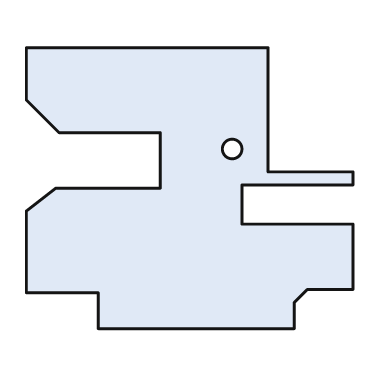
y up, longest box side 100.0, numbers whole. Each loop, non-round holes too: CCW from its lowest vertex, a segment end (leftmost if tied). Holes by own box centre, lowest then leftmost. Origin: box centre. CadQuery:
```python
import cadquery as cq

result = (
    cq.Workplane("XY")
    .moveTo(-28.0, -43.0)
    .lineTo(32.0, -43.0)
    .lineTo(32.0, -35.0)
    .lineTo(36.0, -31.0)
    .lineTo(50.0, -31.0)
    .lineTo(50.0, -11.0)
    .lineTo(16.0, -11.0)
    .lineTo(16.0, 1.0)
    .lineTo(50.0, 1.0)
    .lineTo(50.0, 5.0)
    .lineTo(24.0, 5.0)
    .lineTo(24.0, 43.0)
    .lineTo(-50.0, 43.0)
    .lineTo(-50.0, 27.0)
    .lineTo(-40.0, 17.0)
    .lineTo(-9.0, 17.0)
    .lineTo(-9.0, 0.0)
    .lineTo(-41.0, 0.0)
    .lineTo(-50.0, -7.0)
    .lineTo(-50.0, -32.0)
    .lineTo(-28.0, -32.0)
    .close()
    .moveTo(13.0, 12.0)
    .circle(3.0)
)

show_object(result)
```